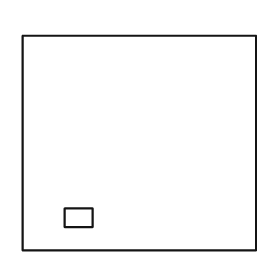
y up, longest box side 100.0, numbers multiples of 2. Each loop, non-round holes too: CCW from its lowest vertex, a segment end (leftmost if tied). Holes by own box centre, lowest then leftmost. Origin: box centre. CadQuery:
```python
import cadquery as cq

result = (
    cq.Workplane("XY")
    .moveTo(-50.0, -46.0)
    .lineTo(50.0, -46.0)
    .lineTo(50.0, 46.0)
    .lineTo(-50.0, 46.0)
    .close()
    .moveTo(-32.0, -36.0)
    .lineTo(-20.0, -36.0)
    .lineTo(-20.0, -28.0)
    .lineTo(-32.0, -28.0)
    .close()
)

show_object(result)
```